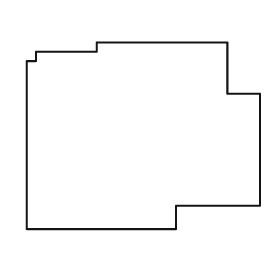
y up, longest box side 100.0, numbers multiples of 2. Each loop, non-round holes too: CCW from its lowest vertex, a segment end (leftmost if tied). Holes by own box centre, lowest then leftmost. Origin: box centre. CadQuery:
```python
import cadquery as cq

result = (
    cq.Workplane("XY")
    .moveTo(-50.0, -40.0)
    .lineTo(14.0, -40.0)
    .lineTo(14.0, -30.0)
    .lineTo(50.0, -30.0)
    .lineTo(50.0, 18.0)
    .lineTo(36.0, 18.0)
    .lineTo(36.0, 40.0)
    .lineTo(-20.0, 40.0)
    .lineTo(-20.0, 36.0)
    .lineTo(-46.0, 36.0)
    .lineTo(-46.0, 32.0)
    .lineTo(-50.0, 32.0)
    .close()
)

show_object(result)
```